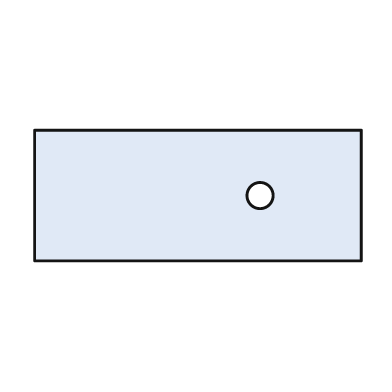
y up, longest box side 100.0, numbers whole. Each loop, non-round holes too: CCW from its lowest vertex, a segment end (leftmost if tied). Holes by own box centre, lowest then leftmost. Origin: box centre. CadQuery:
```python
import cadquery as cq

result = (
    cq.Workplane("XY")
    .moveTo(-50.0, -20.0)
    .lineTo(50.0, -20.0)
    .lineTo(50.0, 20.0)
    .lineTo(-50.0, 20.0)
    .close()
    .moveTo(19.0, 0.0)
    .circle(4.0)
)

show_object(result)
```